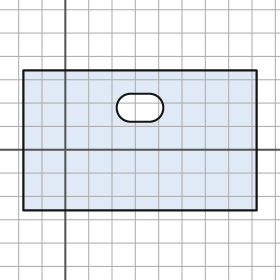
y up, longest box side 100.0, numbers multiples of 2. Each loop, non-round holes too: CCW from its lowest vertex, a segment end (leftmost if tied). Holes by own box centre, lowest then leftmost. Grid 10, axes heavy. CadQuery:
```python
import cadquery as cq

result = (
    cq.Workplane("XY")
    .moveTo(-18.0, -26.0)
    .lineTo(82.0, -26.0)
    .lineTo(82.0, 34.0)
    .lineTo(-18.0, 34.0)
    .close()
    .moveTo(28.0, 12.0)
    .lineTo(36.0, 12.0)
    .threePointArc((42.0, 18.0), (36.0, 24.0))
    .lineTo(28.0, 24.0)
    .threePointArc((22.0, 18.0), (28.0, 12.0))
    .close()
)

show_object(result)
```